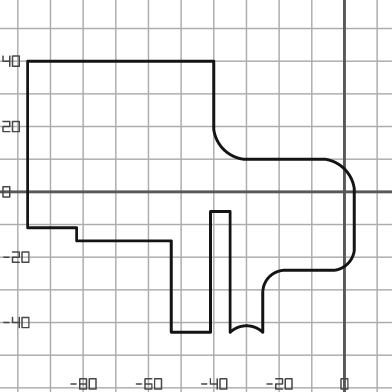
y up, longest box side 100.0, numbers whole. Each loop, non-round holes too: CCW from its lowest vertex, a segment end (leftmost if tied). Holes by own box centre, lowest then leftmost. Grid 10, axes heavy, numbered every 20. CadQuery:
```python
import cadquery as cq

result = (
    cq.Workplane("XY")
    .moveTo(-53.0, -43.0)
    .lineTo(-41.0, -43.0)
    .lineTo(-41.0, -6.0)
    .lineTo(-35.0, -6.0)
    .lineTo(-35.0, -43.0)
    .threePointArc((-30.0, -41.0), (-25.0, -43.0))
    .lineTo(-25.0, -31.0)
    .threePointArc((-23.0, -26.0), (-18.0, -24.0))
    .lineTo(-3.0, -24.0)
    .threePointArc((1.0, -22.0), (3.0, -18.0))
    .lineTo(3.0, 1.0)
    .threePointArc((0.0, 7.0), (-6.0, 10.0))
    .lineTo(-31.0, 10.0)
    .threePointArc((-37.0, 13.0), (-40.0, 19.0))
    .lineTo(-40.0, 40.0)
    .lineTo(-97.0, 40.0)
    .lineTo(-97.0, -11.0)
    .lineTo(-82.0, -11.0)
    .lineTo(-82.0, -15.0)
    .lineTo(-53.0, -15.0)
    .close()
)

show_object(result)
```